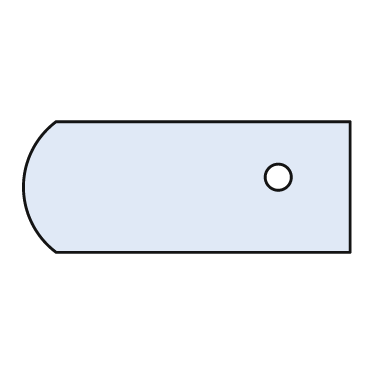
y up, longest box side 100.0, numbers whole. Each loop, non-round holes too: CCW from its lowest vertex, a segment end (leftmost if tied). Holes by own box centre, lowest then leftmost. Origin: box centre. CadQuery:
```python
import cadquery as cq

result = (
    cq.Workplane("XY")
    .moveTo(-40.0, -20.0)
    .lineTo(50.0, -20.0)
    .lineTo(50.0, 20.0)
    .lineTo(-40.0, 20.0)
    .threePointArc((-50.0, 0.0), (-40.0, -20.0))
    .close()
    .moveTo(28.0, 3.0)
    .circle(4.0)
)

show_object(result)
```